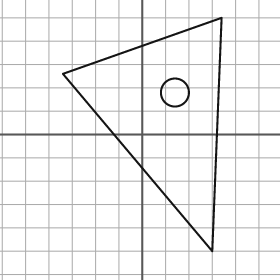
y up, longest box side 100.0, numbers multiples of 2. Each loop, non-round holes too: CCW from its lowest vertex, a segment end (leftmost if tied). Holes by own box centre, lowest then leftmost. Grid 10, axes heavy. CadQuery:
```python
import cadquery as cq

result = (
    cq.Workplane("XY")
    .moveTo(30.0, -50.0)
    .lineTo(34.0, 50.0)
    .lineTo(-34.0, 26.0)
    .close()
    .moveTo(14.0, 18.0)
    .circle(6.0)
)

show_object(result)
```